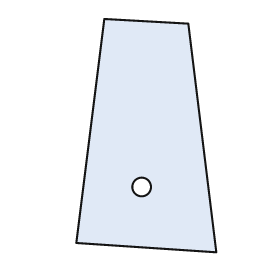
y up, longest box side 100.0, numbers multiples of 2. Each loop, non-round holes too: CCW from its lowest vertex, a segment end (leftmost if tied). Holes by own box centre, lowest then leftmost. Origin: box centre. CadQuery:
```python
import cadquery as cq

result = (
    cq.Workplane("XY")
    .moveTo(30.0, -50.0)
    .lineTo(18.0, 48.0)
    .lineTo(-18.0, 50.0)
    .lineTo(-30.0, -46.0)
    .close()
    .moveTo(-2.0, -22.0)
    .circle(4.0)
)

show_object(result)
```